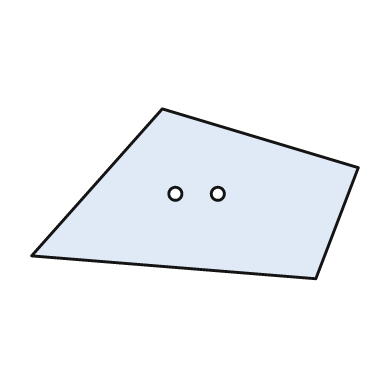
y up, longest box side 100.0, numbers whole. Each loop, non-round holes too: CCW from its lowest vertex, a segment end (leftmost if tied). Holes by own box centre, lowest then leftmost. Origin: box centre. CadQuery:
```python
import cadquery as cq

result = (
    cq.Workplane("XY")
    .moveTo(37.0, -26.0)
    .lineTo(50.0, 8.0)
    .lineTo(-10.0, 26.0)
    .lineTo(-50.0, -19.0)
    .close()
    .moveTo(-6.0, 0.0)
    .circle(2.0)
    .moveTo(7.0, 0.0)
    .circle(2.0)
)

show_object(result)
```